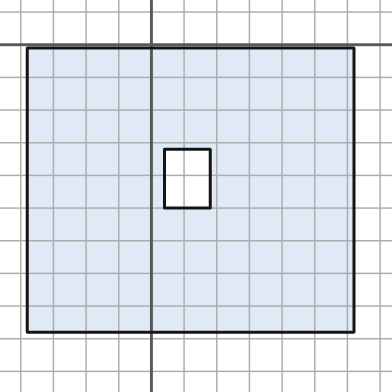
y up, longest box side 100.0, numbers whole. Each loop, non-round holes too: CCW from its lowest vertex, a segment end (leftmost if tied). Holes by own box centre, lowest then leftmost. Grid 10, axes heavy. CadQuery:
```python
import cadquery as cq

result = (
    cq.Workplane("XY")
    .moveTo(-38.0, -88.0)
    .lineTo(62.0, -88.0)
    .lineTo(62.0, -1.0)
    .lineTo(-38.0, -1.0)
    .close()
    .moveTo(4.0, -50.0)
    .lineTo(18.0, -50.0)
    .lineTo(18.0, -32.0)
    .lineTo(4.0, -32.0)
    .close()
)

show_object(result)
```